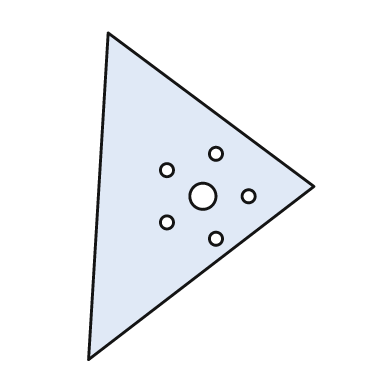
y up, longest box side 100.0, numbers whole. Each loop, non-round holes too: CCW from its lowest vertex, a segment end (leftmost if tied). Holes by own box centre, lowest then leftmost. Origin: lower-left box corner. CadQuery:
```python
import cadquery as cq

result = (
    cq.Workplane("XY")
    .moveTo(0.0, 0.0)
    .lineTo(69.0, 53.0)
    .lineTo(6.0, 100.0)
    .close()
    .moveTo(39.0, 37.0)
    .circle(2.0)
    .moveTo(24.0, 42.0)
    .circle(2.0)
    .moveTo(35.0, 50.0)
    .circle(4.0)
    .moveTo(49.0, 50.0)
    .circle(2.0)
    .moveTo(24.0, 58.0)
    .circle(2.0)
    .moveTo(39.0, 63.0)
    .circle(2.0)
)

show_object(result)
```